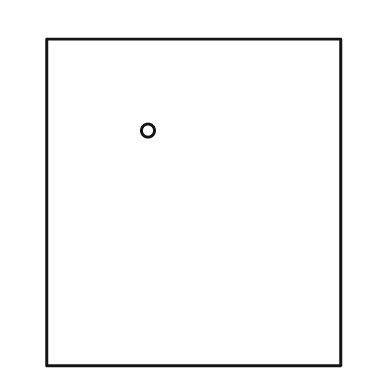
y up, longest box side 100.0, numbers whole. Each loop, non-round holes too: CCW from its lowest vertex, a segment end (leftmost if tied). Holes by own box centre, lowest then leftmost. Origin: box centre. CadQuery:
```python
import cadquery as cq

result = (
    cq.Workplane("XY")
    .moveTo(-45.0, -50.0)
    .lineTo(45.0, -50.0)
    .lineTo(45.0, 50.0)
    .lineTo(-45.0, 50.0)
    .close()
    .moveTo(-14.0, 22.0)
    .circle(2.0)
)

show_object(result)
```